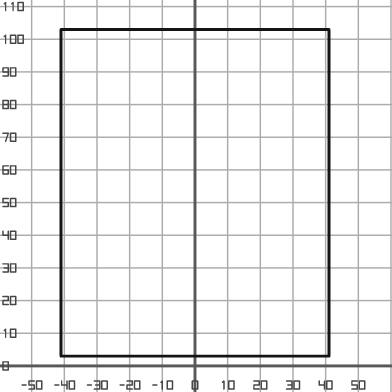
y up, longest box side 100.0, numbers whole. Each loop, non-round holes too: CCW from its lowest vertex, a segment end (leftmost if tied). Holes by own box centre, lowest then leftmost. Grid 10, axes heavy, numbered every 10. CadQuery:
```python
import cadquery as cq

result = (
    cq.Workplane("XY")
    .moveTo(-41.0, 3.0)
    .lineTo(41.0, 3.0)
    .lineTo(41.0, 103.0)
    .lineTo(-41.0, 103.0)
    .close()
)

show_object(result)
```